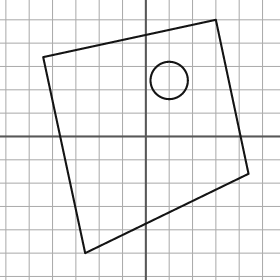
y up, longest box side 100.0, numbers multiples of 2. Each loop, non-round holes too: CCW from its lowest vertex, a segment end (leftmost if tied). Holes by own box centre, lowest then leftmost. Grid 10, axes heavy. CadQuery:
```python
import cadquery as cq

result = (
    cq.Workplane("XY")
    .moveTo(-26.0, -50.0)
    .lineTo(44.0, -16.0)
    .lineTo(30.0, 50.0)
    .lineTo(-44.0, 34.0)
    .close()
    .moveTo(10.0, 24.0)
    .circle(8.0)
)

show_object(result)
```